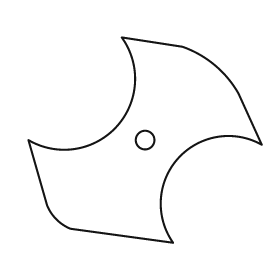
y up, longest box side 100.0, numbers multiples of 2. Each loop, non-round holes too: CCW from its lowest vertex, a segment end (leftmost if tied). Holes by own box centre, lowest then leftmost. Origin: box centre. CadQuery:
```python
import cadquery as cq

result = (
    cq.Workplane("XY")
    .moveTo(12.0, -44.0)
    .threePointArc((14.0, -8.0), (50.0, -2.0))
    .lineTo(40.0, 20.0)
    .threePointArc((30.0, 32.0), (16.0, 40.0))
    .lineTo(-10.0, 44.0)
    .threePointArc((-12.0, 6.0), (-50.0, 0.0))
    .lineTo(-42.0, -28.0)
    .threePointArc((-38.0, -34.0), (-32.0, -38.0))
    .close()
    .moveTo(0.0, 0.0)
    .circle(4.0)
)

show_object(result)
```